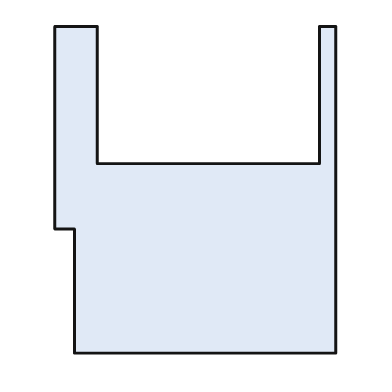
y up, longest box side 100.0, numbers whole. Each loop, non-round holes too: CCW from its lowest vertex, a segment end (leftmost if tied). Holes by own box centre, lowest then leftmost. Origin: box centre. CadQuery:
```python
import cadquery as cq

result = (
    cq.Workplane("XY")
    .moveTo(-37.0, -50.0)
    .lineTo(43.0, -50.0)
    .lineTo(43.0, 50.0)
    .lineTo(38.0, 50.0)
    .lineTo(38.0, 8.0)
    .lineTo(-30.0, 8.0)
    .lineTo(-30.0, 50.0)
    .lineTo(-43.0, 50.0)
    .lineTo(-43.0, -12.0)
    .lineTo(-37.0, -12.0)
    .close()
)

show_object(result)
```